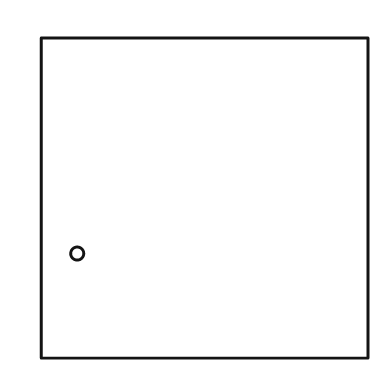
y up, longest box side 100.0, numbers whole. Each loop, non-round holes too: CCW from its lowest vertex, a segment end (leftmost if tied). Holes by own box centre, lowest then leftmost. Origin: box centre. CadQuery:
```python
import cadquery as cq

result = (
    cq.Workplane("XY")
    .moveTo(-50.0, -49.0)
    .lineTo(50.0, -49.0)
    .lineTo(50.0, 49.0)
    .lineTo(-50.0, 49.0)
    .close()
    .moveTo(-39.0, -17.0)
    .circle(2.0)
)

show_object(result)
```